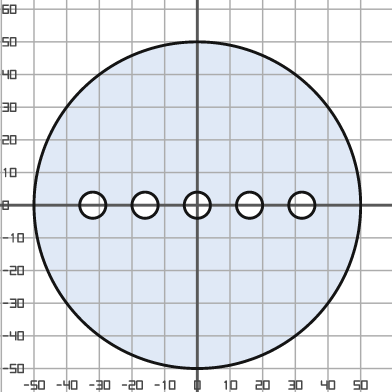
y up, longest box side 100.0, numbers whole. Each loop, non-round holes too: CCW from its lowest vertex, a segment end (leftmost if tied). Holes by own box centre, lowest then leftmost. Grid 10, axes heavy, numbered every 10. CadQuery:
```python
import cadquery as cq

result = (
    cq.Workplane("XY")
    .moveTo(0.0, 0.0)
    .circle(50.0)
    .moveTo(-32.0, 0.0)
    .circle(4.0)
    .moveTo(-16.0, 0.0)
    .circle(4.0)
    .moveTo(0.0, 0.0)
    .circle(4.0)
    .moveTo(16.0, 0.0)
    .circle(4.0)
    .moveTo(32.0, 0.0)
    .circle(4.0)
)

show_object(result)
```